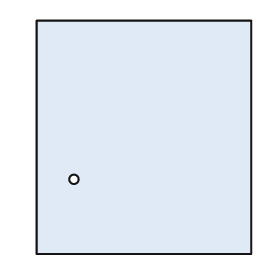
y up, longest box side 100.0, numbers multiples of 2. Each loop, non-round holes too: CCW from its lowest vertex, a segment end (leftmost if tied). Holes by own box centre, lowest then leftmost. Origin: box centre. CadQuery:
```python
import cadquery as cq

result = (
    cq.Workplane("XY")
    .moveTo(-46.0, -50.0)
    .lineTo(46.0, -50.0)
    .lineTo(46.0, 50.0)
    .lineTo(-46.0, 50.0)
    .close()
    .moveTo(-30.0, -18.0)
    .circle(2.0)
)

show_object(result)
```